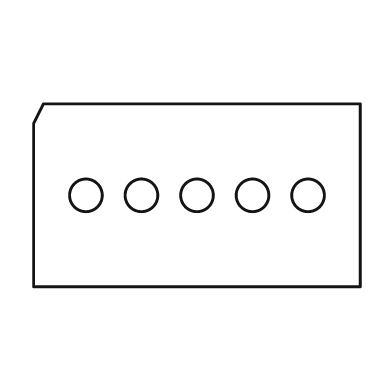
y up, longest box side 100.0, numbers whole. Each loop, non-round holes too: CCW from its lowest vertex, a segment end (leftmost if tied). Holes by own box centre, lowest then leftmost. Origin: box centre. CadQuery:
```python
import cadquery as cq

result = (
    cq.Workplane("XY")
    .moveTo(-50.0, -28.0)
    .lineTo(50.0, -28.0)
    .lineTo(50.0, 28.0)
    .lineTo(-47.0, 28.0)
    .lineTo(-50.0, 22.0)
    .close()
    .moveTo(-34.0, 0.0)
    .circle(5.0)
    .moveTo(-17.0, 0.0)
    .circle(5.0)
    .moveTo(0.0, 0.0)
    .circle(5.0)
    .moveTo(17.0, 0.0)
    .circle(5.0)
    .moveTo(34.0, 0.0)
    .circle(5.0)
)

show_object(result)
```